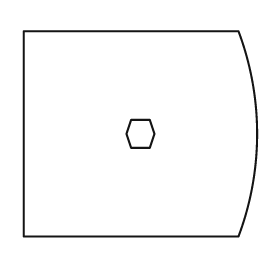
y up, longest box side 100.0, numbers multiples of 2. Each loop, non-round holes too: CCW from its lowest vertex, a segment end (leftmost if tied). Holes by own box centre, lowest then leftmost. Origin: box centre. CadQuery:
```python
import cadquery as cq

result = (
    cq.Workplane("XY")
    .moveTo(-50.0, -44.0)
    .lineTo(42.0, -44.0)
    .threePointArc((50.0, 0.0), (42.0, 44.0))
    .lineTo(-50.0, 44.0)
    .close()
    .moveTo(-4.0, -6.0)
    .lineTo(4.0, -6.0)
    .lineTo(6.0, 0.0)
    .lineTo(4.0, 6.0)
    .lineTo(-4.0, 6.0)
    .lineTo(-6.0, 0.0)
    .close()
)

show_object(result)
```